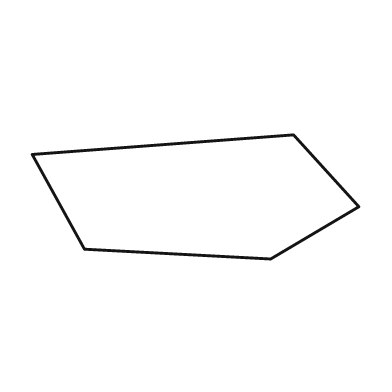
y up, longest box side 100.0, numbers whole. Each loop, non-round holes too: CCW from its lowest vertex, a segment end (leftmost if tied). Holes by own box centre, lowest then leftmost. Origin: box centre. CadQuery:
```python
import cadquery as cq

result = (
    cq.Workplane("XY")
    .moveTo(23.0, -19.0)
    .lineTo(50.0, -3.0)
    .lineTo(30.0, 19.0)
    .lineTo(-50.0, 13.0)
    .lineTo(-34.0, -16.0)
    .close()
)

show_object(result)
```